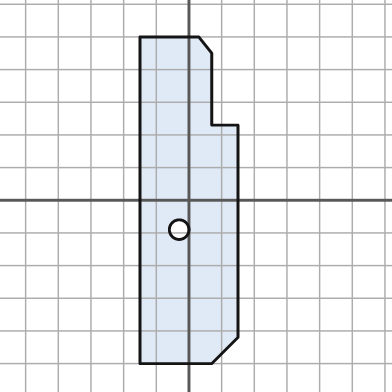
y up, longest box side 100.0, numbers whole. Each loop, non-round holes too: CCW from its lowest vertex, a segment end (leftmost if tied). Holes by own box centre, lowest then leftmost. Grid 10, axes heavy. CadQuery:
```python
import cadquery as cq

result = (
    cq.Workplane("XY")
    .moveTo(-15.0, -50.0)
    .lineTo(7.0, -50.0)
    .lineTo(15.0, -42.0)
    .lineTo(15.0, 23.0)
    .lineTo(7.0, 23.0)
    .lineTo(7.0, 45.0)
    .lineTo(3.0, 50.0)
    .lineTo(-15.0, 50.0)
    .close()
    .moveTo(-3.0, -9.0)
    .circle(3.0)
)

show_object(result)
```